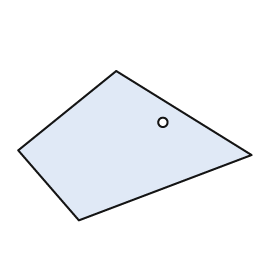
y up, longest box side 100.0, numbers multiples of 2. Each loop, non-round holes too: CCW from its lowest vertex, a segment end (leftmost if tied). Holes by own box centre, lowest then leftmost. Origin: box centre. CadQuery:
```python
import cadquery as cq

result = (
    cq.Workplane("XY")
    .moveTo(-24.0, -32.0)
    .lineTo(50.0, -4.0)
    .lineTo(-8.0, 32.0)
    .lineTo(-50.0, -2.0)
    .close()
    .moveTo(12.0, 10.0)
    .circle(2.0)
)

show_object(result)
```